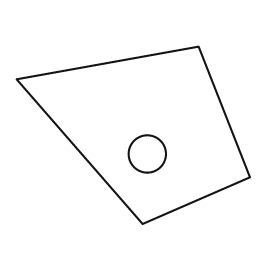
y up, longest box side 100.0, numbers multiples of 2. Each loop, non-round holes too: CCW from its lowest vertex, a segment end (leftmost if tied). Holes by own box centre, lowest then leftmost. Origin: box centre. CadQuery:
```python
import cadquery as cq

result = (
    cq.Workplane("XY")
    .moveTo(4.0, -38.0)
    .lineTo(50.0, -18.0)
    .lineTo(28.0, 38.0)
    .lineTo(-50.0, 24.0)
    .close()
    .moveTo(6.0, -8.0)
    .circle(8.0)
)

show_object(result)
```